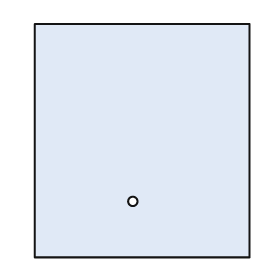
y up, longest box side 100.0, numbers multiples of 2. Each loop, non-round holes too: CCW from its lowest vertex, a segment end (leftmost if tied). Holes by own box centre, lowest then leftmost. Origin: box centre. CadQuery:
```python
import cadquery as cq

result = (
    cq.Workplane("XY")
    .moveTo(-46.0, -50.0)
    .lineTo(46.0, -50.0)
    .lineTo(46.0, 50.0)
    .lineTo(-46.0, 50.0)
    .close()
    .moveTo(-4.0, -26.0)
    .circle(2.0)
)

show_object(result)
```